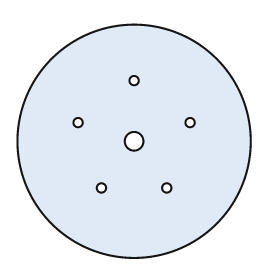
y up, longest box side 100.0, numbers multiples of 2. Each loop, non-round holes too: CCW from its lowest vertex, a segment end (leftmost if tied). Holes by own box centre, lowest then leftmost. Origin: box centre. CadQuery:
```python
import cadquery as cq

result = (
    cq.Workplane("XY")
    .moveTo(0.0, 0.0)
    .circle(50.0)
    .moveTo(-14.0, -20.0)
    .circle(2.0)
    .moveTo(14.0, -20.0)
    .circle(2.0)
    .moveTo(0.0, 0.0)
    .circle(4.0)
    .moveTo(-24.0, 8.0)
    .circle(2.0)
    .moveTo(24.0, 8.0)
    .circle(2.0)
    .moveTo(0.0, 26.0)
    .circle(2.0)
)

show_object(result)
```